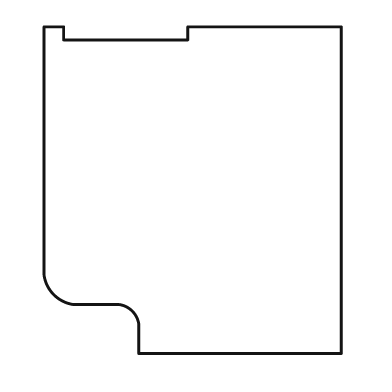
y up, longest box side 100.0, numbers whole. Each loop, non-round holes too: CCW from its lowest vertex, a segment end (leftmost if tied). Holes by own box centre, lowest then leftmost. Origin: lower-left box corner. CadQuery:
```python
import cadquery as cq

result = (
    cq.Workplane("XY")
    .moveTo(29.0, 0.0)
    .lineTo(91.0, 0.0)
    .lineTo(91.0, 100.0)
    .lineTo(44.0, 100.0)
    .lineTo(44.0, 96.0)
    .lineTo(6.0, 96.0)
    .lineTo(6.0, 100.0)
    .lineTo(0.0, 100.0)
    .lineTo(0.0, 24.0)
    .threePointArc((3.0, 18.0), (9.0, 15.0))
    .lineTo(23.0, 15.0)
    .threePointArc((27.0, 13.0), (29.0, 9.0))
    .close()
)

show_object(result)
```